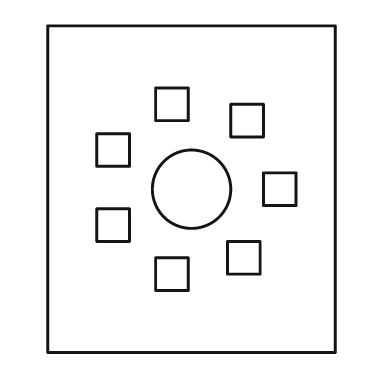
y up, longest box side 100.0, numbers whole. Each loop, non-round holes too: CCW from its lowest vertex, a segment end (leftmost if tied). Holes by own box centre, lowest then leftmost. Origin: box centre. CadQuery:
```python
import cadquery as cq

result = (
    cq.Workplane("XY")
    .moveTo(-44.0, -50.0)
    .lineTo(44.0, -50.0)
    .lineTo(44.0, 50.0)
    .lineTo(-44.0, 50.0)
    .close()
    .moveTo(-11.0, -31.0)
    .lineTo(-1.0, -31.0)
    .lineTo(-1.0, -21.0)
    .lineTo(-11.0, -21.0)
    .close()
    .moveTo(11.0, -26.0)
    .lineTo(21.0, -26.0)
    .lineTo(21.0, -16.0)
    .lineTo(11.0, -16.0)
    .close()
    .moveTo(-29.0, -16.0)
    .lineTo(-19.0, -16.0)
    .lineTo(-19.0, -6.0)
    .lineTo(-29.0, -6.0)
    .close()
    .moveTo(0.0, 0.0)
    .circle(12.0)
    .moveTo(22.0, -5.0)
    .lineTo(32.0, -5.0)
    .lineTo(32.0, 5.0)
    .lineTo(22.0, 5.0)
    .close()
    .moveTo(-29.0, 7.0)
    .lineTo(-19.0, 7.0)
    .lineTo(-19.0, 17.0)
    .lineTo(-29.0, 17.0)
    .close()
    .moveTo(12.0, 16.0)
    .lineTo(22.0, 16.0)
    .lineTo(22.0, 26.0)
    .lineTo(12.0, 26.0)
    .close()
    .moveTo(-11.0, 21.0)
    .lineTo(-1.0, 21.0)
    .lineTo(-1.0, 31.0)
    .lineTo(-11.0, 31.0)
    .close()
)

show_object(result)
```